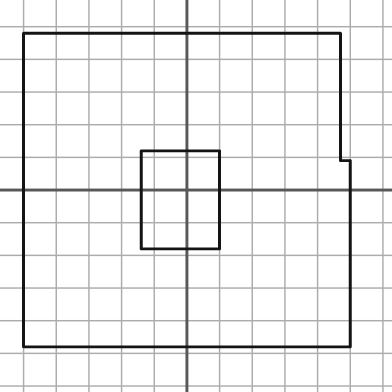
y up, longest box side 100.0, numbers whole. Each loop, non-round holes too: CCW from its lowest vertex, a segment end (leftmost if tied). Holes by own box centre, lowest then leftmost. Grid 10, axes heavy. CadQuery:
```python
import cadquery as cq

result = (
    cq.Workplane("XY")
    .moveTo(-50.0, -48.0)
    .lineTo(50.0, -48.0)
    .lineTo(50.0, 9.0)
    .lineTo(47.0, 9.0)
    .lineTo(47.0, 48.0)
    .lineTo(-50.0, 48.0)
    .close()
    .moveTo(-14.0, -18.0)
    .lineTo(10.0, -18.0)
    .lineTo(10.0, 12.0)
    .lineTo(-14.0, 12.0)
    .close()
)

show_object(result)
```